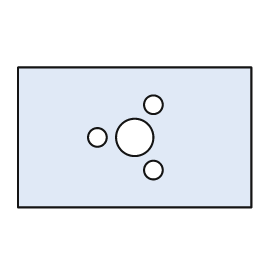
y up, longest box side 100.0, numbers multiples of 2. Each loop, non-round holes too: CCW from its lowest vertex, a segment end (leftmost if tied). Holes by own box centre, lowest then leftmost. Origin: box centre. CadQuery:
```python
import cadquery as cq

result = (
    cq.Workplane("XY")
    .moveTo(-50.0, -30.0)
    .lineTo(50.0, -30.0)
    .lineTo(50.0, 30.0)
    .lineTo(-50.0, 30.0)
    .close()
    .moveTo(8.0, -14.0)
    .circle(4.0)
    .moveTo(-16.0, 0.0)
    .circle(4.0)
    .moveTo(0.0, 0.0)
    .circle(8.0)
    .moveTo(8.0, 14.0)
    .circle(4.0)
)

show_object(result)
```